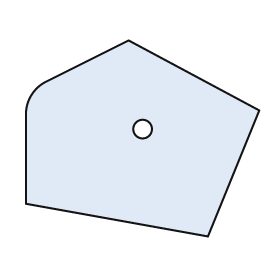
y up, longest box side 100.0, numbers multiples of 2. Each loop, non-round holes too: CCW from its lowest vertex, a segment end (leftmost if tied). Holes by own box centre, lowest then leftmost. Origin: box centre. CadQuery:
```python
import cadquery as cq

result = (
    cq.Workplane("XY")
    .moveTo(28.0, -42.0)
    .lineTo(50.0, 12.0)
    .lineTo(-6.0, 42.0)
    .lineTo(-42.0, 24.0)
    .threePointArc((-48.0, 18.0), (-50.0, 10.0))
    .lineTo(-50.0, -28.0)
    .close()
    .moveTo(0.0, 4.0)
    .circle(4.0)
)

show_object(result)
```